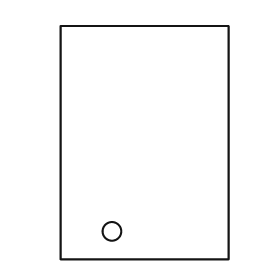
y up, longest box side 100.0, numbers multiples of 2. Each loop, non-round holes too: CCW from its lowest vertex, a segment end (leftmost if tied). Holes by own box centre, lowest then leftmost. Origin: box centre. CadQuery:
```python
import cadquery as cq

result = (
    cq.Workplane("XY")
    .moveTo(-36.0, -50.0)
    .lineTo(36.0, -50.0)
    .lineTo(36.0, 50.0)
    .lineTo(-36.0, 50.0)
    .close()
    .moveTo(-14.0, -38.0)
    .circle(4.0)
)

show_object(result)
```